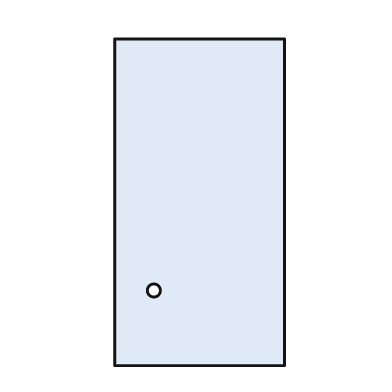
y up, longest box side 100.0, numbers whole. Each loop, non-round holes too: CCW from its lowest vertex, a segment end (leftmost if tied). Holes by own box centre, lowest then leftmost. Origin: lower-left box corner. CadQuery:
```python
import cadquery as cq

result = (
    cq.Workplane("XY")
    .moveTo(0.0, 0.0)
    .lineTo(52.0, 0.0)
    .lineTo(52.0, 100.0)
    .lineTo(0.0, 100.0)
    .close()
    .moveTo(12.0, 23.0)
    .circle(2.0)
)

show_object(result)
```